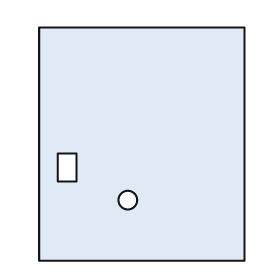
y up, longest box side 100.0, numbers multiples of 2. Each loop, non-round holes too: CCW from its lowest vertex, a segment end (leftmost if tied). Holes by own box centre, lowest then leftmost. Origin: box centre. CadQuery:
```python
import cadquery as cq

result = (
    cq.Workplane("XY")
    .moveTo(-44.0, -50.0)
    .lineTo(44.0, -50.0)
    .lineTo(44.0, 50.0)
    .lineTo(-44.0, 50.0)
    .close()
    .moveTo(-6.0, -24.0)
    .circle(4.0)
    .moveTo(-36.0, -16.0)
    .lineTo(-28.0, -16.0)
    .lineTo(-28.0, -4.0)
    .lineTo(-36.0, -4.0)
    .close()
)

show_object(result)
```